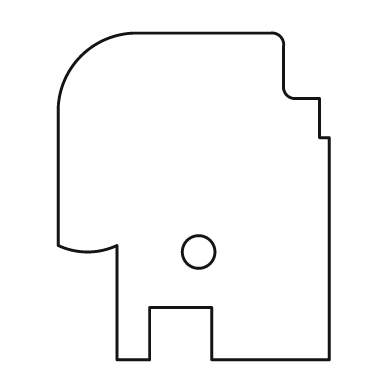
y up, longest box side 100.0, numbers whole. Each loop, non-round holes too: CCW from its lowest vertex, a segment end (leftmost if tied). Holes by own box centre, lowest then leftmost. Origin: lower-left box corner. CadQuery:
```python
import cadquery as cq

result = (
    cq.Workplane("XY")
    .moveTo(18.0, 0.0)
    .lineTo(28.0, 0.0)
    .lineTo(28.0, 16.0)
    .lineTo(47.0, 16.0)
    .lineTo(47.0, 0.0)
    .lineTo(83.0, 0.0)
    .lineTo(83.0, 68.0)
    .lineTo(80.0, 68.0)
    .lineTo(80.0, 80.0)
    .lineTo(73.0, 80.0)
    .threePointArc((70.0, 81.0), (69.0, 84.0))
    .lineTo(69.0, 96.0)
    .threePointArc((68.0, 99.0), (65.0, 100.0))
    .lineTo(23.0, 100.0)
    .threePointArc((7.0, 93.0), (0.0, 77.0))
    .lineTo(0.0, 35.0)
    .threePointArc((9.0, 33.0), (18.0, 35.0))
    .close()
    .moveTo(43.0, 33.0)
    .circle(5.0)
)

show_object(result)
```